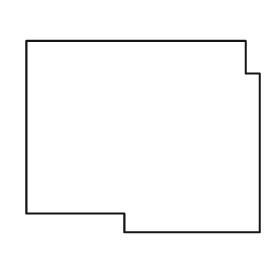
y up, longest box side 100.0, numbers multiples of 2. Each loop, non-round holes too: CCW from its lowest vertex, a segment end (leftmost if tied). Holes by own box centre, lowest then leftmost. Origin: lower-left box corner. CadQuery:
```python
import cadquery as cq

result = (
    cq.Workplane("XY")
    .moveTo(42.0, 0.0)
    .lineTo(100.0, 0.0)
    .lineTo(100.0, 68.0)
    .lineTo(94.0, 68.0)
    .lineTo(94.0, 82.0)
    .lineTo(0.0, 82.0)
    .lineTo(0.0, 8.0)
    .lineTo(42.0, 8.0)
    .close()
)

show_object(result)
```